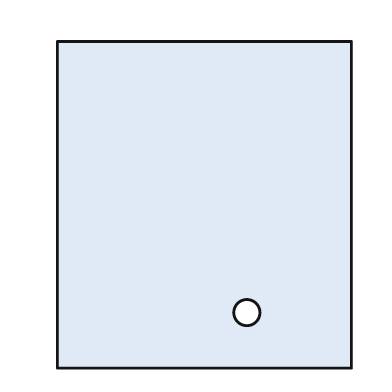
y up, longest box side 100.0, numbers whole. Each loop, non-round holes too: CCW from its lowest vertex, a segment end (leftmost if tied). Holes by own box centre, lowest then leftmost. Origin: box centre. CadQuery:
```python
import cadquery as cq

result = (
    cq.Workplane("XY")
    .moveTo(-45.0, -50.0)
    .lineTo(45.0, -50.0)
    .lineTo(45.0, 50.0)
    .lineTo(-45.0, 50.0)
    .close()
    .moveTo(13.0, -33.0)
    .circle(4.0)
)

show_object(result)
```